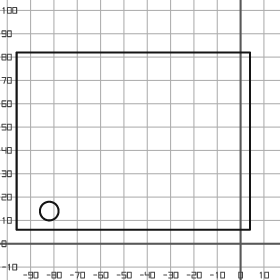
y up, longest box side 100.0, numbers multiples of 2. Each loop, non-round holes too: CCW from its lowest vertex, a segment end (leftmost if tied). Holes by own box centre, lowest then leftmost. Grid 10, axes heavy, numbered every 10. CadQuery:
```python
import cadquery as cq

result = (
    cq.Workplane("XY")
    .moveTo(-96.0, 6.0)
    .lineTo(4.0, 6.0)
    .lineTo(4.0, 82.0)
    .lineTo(-96.0, 82.0)
    .close()
    .moveTo(-82.0, 14.0)
    .circle(4.0)
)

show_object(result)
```